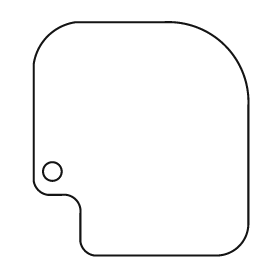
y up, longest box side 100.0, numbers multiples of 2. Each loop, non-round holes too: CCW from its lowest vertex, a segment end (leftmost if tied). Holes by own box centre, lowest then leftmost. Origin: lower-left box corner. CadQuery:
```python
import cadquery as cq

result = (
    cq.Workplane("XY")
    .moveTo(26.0, 0.0)
    .lineTo(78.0, 0.0)
    .threePointArc((88.0, 4.0), (92.0, 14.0))
    .lineTo(92.0, 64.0)
    .threePointArc((82.0, 90.0), (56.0, 100.0))
    .lineTo(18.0, 100.0)
    .threePointArc((6.0, 94.0), (0.0, 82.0))
    .lineTo(0.0, 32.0)
    .threePointArc((2.0, 28.0), (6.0, 26.0))
    .lineTo(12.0, 26.0)
    .threePointArc((18.0, 24.0), (20.0, 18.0))
    .lineTo(20.0, 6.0)
    .threePointArc((22.0, 2.0), (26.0, 0.0))
    .close()
    .moveTo(8.0, 36.0)
    .circle(4.0)
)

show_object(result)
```